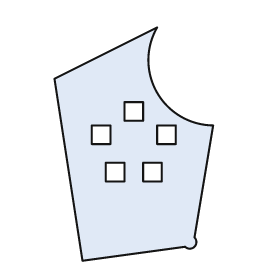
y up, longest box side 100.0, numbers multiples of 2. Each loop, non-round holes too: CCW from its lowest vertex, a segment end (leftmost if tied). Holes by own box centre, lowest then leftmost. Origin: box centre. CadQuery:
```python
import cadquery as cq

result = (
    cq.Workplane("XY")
    .moveTo(-22.0, -50.0)
    .lineTo(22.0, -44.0)
    .threePointArc((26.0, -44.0), (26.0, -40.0))
    .lineTo(34.0, 8.0)
    .threePointArc((10.0, 22.0), (10.0, 50.0))
    .lineTo(-34.0, 28.0)
    .close()
    .moveTo(-12.0, -16.0)
    .lineTo(-4.0, -16.0)
    .lineTo(-4.0, -8.0)
    .lineTo(-12.0, -8.0)
    .close()
    .moveTo(4.0, -16.0)
    .lineTo(12.0, -16.0)
    .lineTo(12.0, -8.0)
    .lineTo(4.0, -8.0)
    .close()
    .moveTo(-18.0, 0.0)
    .lineTo(-10.0, 0.0)
    .lineTo(-10.0, 8.0)
    .lineTo(-18.0, 8.0)
    .close()
    .moveTo(10.0, 0.0)
    .lineTo(18.0, 0.0)
    .lineTo(18.0, 8.0)
    .lineTo(10.0, 8.0)
    .close()
    .moveTo(-4.0, 10.0)
    .lineTo(4.0, 10.0)
    .lineTo(4.0, 18.0)
    .lineTo(-4.0, 18.0)
    .close()
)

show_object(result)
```